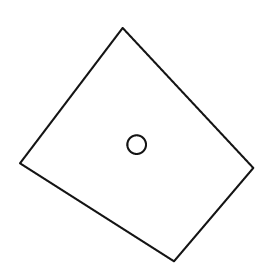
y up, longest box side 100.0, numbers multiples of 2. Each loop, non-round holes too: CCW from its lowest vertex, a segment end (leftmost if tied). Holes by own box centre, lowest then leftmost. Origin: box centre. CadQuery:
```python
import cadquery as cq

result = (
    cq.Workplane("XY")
    .moveTo(16.0, -50.0)
    .lineTo(50.0, -10.0)
    .lineTo(-6.0, 50.0)
    .lineTo(-50.0, -8.0)
    .close()
    .moveTo(0.0, 0.0)
    .circle(4.0)
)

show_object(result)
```